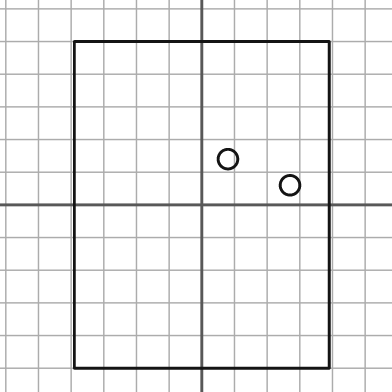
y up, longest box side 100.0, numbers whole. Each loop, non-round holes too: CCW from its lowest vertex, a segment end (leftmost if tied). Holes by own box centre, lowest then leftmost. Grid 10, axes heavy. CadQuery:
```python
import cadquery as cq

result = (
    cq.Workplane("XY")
    .moveTo(-39.0, -50.0)
    .lineTo(39.0, -50.0)
    .lineTo(39.0, 50.0)
    .lineTo(-39.0, 50.0)
    .close()
    .moveTo(27.0, 6.0)
    .circle(3.0)
    .moveTo(8.0, 14.0)
    .circle(3.0)
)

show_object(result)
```